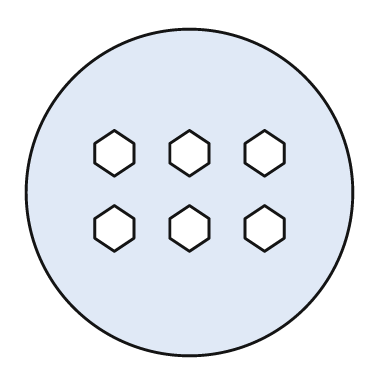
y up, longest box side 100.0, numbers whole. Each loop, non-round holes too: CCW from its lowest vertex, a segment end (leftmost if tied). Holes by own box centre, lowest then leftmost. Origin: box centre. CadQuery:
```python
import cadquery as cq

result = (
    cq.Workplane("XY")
    .moveTo(0.0, 0.0)
    .circle(50.0)
    .moveTo(-23.0, -18.0)
    .lineTo(-17.0, -14.0)
    .lineTo(-17.0, -8.0)
    .lineTo(-23.0, -4.0)
    .lineTo(-29.0, -8.0)
    .lineTo(-29.0, -14.0)
    .close()
    .moveTo(0.0, -18.0)
    .lineTo(6.0, -14.0)
    .lineTo(6.0, -8.0)
    .lineTo(0.0, -4.0)
    .lineTo(-6.0, -8.0)
    .lineTo(-6.0, -14.0)
    .close()
    .moveTo(23.0, -18.0)
    .lineTo(29.0, -14.0)
    .lineTo(29.0, -8.0)
    .lineTo(23.0, -4.0)
    .lineTo(17.0, -8.0)
    .lineTo(17.0, -14.0)
    .close()
    .moveTo(-23.0, 5.0)
    .lineTo(-17.0, 9.0)
    .lineTo(-17.0, 15.0)
    .lineTo(-23.0, 19.0)
    .lineTo(-29.0, 15.0)
    .lineTo(-29.0, 9.0)
    .close()
    .moveTo(0.0, 5.0)
    .lineTo(6.0, 9.0)
    .lineTo(6.0, 15.0)
    .lineTo(0.0, 19.0)
    .lineTo(-6.0, 15.0)
    .lineTo(-6.0, 9.0)
    .close()
    .moveTo(23.0, 5.0)
    .lineTo(29.0, 9.0)
    .lineTo(29.0, 15.0)
    .lineTo(23.0, 19.0)
    .lineTo(17.0, 15.0)
    .lineTo(17.0, 9.0)
    .close()
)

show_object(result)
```